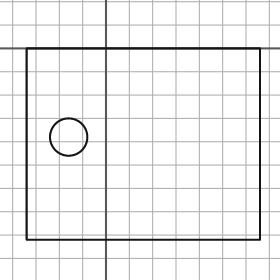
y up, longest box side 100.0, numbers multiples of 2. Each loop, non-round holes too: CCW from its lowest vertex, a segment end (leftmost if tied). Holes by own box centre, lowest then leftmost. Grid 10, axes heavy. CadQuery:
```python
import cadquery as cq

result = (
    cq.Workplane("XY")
    .moveTo(-34.0, -82.0)
    .lineTo(66.0, -82.0)
    .lineTo(66.0, 0.0)
    .lineTo(-34.0, 0.0)
    .close()
    .moveTo(-16.0, -38.0)
    .circle(8.0)
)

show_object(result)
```